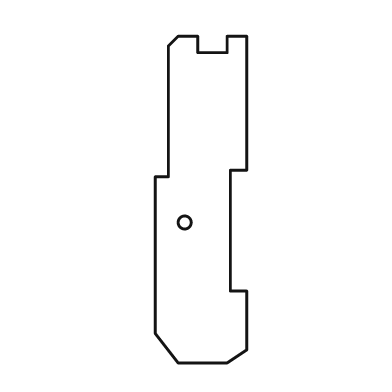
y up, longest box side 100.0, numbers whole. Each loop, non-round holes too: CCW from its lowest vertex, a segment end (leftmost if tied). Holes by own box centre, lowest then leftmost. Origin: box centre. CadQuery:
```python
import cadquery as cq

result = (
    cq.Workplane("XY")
    .moveTo(-7.0, -50.0)
    .lineTo(8.0, -50.0)
    .lineTo(14.0, -46.0)
    .lineTo(14.0, -28.0)
    .lineTo(9.0, -28.0)
    .lineTo(9.0, 9.0)
    .lineTo(14.0, 9.0)
    .lineTo(14.0, 50.0)
    .lineTo(8.0, 50.0)
    .lineTo(8.0, 45.0)
    .lineTo(-1.0, 45.0)
    .lineTo(-1.0, 50.0)
    .lineTo(-7.0, 50.0)
    .lineTo(-10.0, 47.0)
    .lineTo(-10.0, 7.0)
    .lineTo(-14.0, 7.0)
    .lineTo(-14.0, -41.0)
    .close()
    .moveTo(-5.0, -7.0)
    .circle(2.0)
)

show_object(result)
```